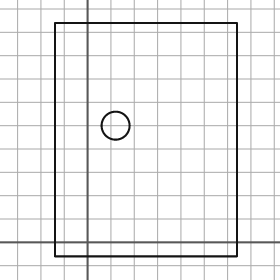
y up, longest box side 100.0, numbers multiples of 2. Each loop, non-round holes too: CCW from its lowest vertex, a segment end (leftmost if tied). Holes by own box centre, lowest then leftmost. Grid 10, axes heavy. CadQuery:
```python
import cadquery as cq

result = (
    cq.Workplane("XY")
    .moveTo(-14.0, -6.0)
    .lineTo(64.0, -6.0)
    .lineTo(64.0, 94.0)
    .lineTo(-14.0, 94.0)
    .close()
    .moveTo(12.0, 50.0)
    .circle(6.0)
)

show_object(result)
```